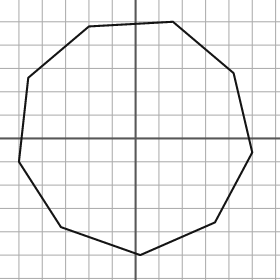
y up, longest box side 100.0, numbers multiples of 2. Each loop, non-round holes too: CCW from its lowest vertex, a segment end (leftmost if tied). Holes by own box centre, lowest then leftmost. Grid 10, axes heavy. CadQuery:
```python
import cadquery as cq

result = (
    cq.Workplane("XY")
    .moveTo(2.0, -50.0)
    .lineTo(34.0, -36.0)
    .lineTo(50.0, -6.0)
    .lineTo(42.0, 28.0)
    .lineTo(16.0, 50.0)
    .lineTo(-20.0, 48.0)
    .lineTo(-46.0, 26.0)
    .lineTo(-50.0, -10.0)
    .lineTo(-32.0, -38.0)
    .close()
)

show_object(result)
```